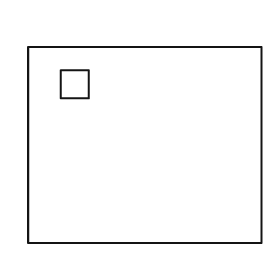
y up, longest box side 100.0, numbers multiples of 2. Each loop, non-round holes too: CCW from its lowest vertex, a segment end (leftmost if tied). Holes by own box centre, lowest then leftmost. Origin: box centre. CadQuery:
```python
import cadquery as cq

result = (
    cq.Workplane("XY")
    .moveTo(-50.0, -42.0)
    .lineTo(50.0, -42.0)
    .lineTo(50.0, 42.0)
    .lineTo(-50.0, 42.0)
    .close()
    .moveTo(-36.0, 20.0)
    .lineTo(-24.0, 20.0)
    .lineTo(-24.0, 32.0)
    .lineTo(-36.0, 32.0)
    .close()
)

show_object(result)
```